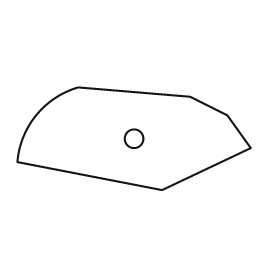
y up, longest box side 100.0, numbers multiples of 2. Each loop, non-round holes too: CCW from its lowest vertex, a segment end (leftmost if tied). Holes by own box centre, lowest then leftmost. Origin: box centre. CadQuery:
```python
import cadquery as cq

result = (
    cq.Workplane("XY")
    .moveTo(12.0, -22.0)
    .lineTo(50.0, -4.0)
    .lineTo(40.0, 10.0)
    .lineTo(24.0, 18.0)
    .lineTo(-24.0, 22.0)
    .threePointArc((-42.0, 10.0), (-50.0, -10.0))
    .close()
    .moveTo(0.0, 0.0)
    .circle(4.0)
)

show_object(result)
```